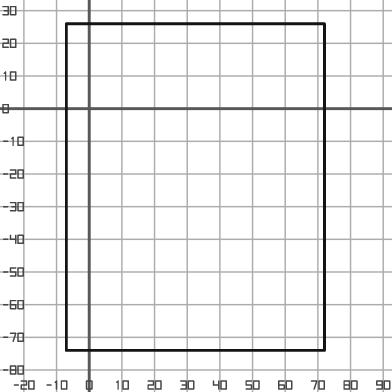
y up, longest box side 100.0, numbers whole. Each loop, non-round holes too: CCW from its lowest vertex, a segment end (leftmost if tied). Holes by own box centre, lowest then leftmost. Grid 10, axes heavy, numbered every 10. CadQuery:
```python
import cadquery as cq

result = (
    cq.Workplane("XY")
    .moveTo(-7.0, -74.0)
    .lineTo(72.0, -74.0)
    .lineTo(72.0, 26.0)
    .lineTo(-7.0, 26.0)
    .close()
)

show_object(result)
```